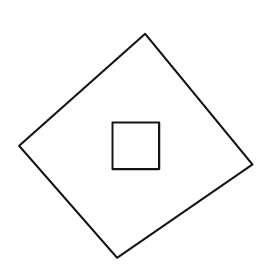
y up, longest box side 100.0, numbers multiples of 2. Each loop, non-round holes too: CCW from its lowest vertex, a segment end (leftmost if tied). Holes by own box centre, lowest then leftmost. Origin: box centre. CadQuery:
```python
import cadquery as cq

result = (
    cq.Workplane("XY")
    .moveTo(-8.0, -48.0)
    .lineTo(50.0, -8.0)
    .lineTo(4.0, 48.0)
    .lineTo(-50.0, 0.0)
    .close()
    .moveTo(-10.0, -10.0)
    .lineTo(10.0, -10.0)
    .lineTo(10.0, 10.0)
    .lineTo(-10.0, 10.0)
    .close()
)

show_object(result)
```